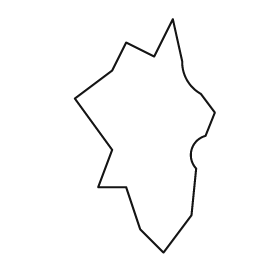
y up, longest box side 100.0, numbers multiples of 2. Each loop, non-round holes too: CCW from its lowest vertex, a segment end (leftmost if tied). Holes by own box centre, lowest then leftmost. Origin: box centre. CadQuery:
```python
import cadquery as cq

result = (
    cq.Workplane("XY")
    .moveTo(8.0, -50.0)
    .lineTo(20.0, -34.0)
    .lineTo(22.0, -14.0)
    .threePointArc((20.0, -6.0), (26.0, 0.0))
    .lineTo(30.0, 10.0)
    .lineTo(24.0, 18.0)
    .threePointArc((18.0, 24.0), (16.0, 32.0))
    .lineTo(12.0, 50.0)
    .lineTo(4.0, 34.0)
    .lineTo(-8.0, 40.0)
    .lineTo(-14.0, 28.0)
    .lineTo(-30.0, 16.0)
    .lineTo(-14.0, -6.0)
    .lineTo(-20.0, -22.0)
    .lineTo(-8.0, -22.0)
    .lineTo(-2.0, -40.0)
    .close()
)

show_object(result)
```